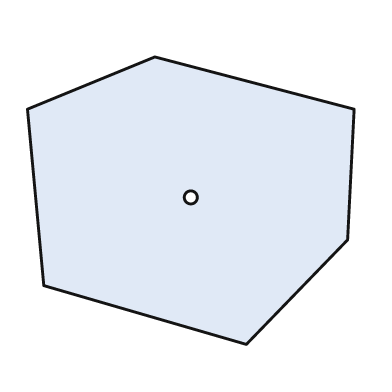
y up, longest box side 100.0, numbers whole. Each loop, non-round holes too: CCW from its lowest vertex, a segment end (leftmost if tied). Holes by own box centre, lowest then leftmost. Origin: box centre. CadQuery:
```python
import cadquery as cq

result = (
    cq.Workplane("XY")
    .moveTo(17.0, -44.0)
    .lineTo(48.0, -12.0)
    .lineTo(50.0, 28.0)
    .lineTo(-11.0, 44.0)
    .lineTo(-50.0, 28.0)
    .lineTo(-45.0, -26.0)
    .close()
    .moveTo(0.0, 1.0)
    .circle(2.0)
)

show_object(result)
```